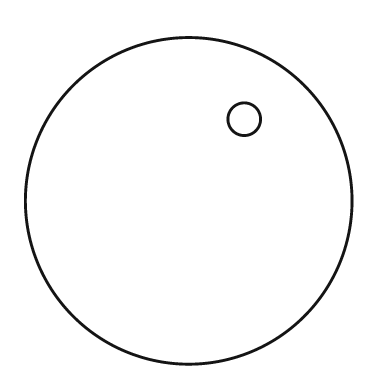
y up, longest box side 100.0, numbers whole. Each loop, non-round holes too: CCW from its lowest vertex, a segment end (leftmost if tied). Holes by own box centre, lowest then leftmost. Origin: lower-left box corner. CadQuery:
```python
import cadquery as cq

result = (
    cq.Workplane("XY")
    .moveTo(50.0, 50.0)
    .circle(50.0)
    .moveTo(67.0, 75.0)
    .circle(5.0)
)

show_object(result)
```